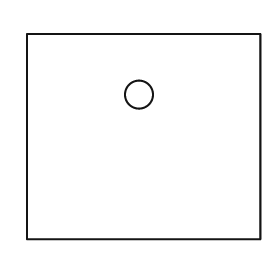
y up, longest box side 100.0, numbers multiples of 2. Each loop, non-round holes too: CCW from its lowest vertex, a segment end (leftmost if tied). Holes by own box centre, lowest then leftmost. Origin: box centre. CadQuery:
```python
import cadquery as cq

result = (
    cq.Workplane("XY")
    .moveTo(-50.0, -44.0)
    .lineTo(50.0, -44.0)
    .lineTo(50.0, 44.0)
    .lineTo(-50.0, 44.0)
    .close()
    .moveTo(-2.0, 18.0)
    .circle(6.0)
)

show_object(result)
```